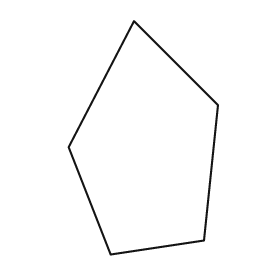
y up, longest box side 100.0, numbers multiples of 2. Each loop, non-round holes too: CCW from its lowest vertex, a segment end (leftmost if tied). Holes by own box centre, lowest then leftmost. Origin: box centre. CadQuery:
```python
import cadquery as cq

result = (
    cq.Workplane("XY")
    .moveTo(-14.0, -50.0)
    .lineTo(26.0, -44.0)
    .lineTo(32.0, 14.0)
    .lineTo(-4.0, 50.0)
    .lineTo(-32.0, -4.0)
    .close()
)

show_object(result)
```